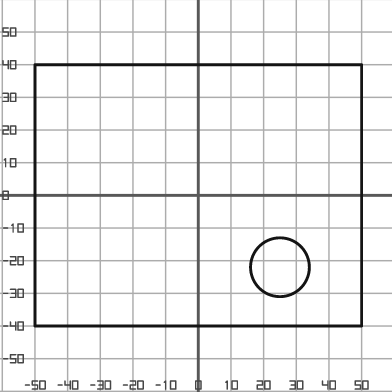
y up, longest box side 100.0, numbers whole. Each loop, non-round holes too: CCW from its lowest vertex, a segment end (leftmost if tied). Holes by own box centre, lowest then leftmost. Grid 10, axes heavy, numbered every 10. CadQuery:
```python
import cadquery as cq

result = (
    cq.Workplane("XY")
    .moveTo(-50.0, -40.0)
    .lineTo(50.0, -40.0)
    .lineTo(50.0, 40.0)
    .lineTo(-50.0, 40.0)
    .close()
    .moveTo(25.0, -22.0)
    .circle(9.0)
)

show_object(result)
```